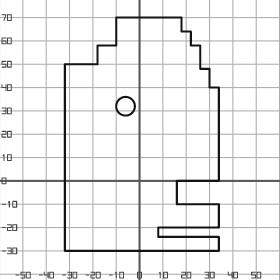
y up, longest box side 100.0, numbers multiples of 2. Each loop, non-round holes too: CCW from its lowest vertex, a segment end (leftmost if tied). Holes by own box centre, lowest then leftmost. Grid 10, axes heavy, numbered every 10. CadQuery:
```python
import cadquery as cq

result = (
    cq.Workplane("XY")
    .moveTo(-32.0, -30.0)
    .lineTo(34.0, -30.0)
    .lineTo(34.0, -24.0)
    .lineTo(8.0, -24.0)
    .lineTo(8.0, -20.0)
    .lineTo(34.0, -20.0)
    .lineTo(34.0, -10.0)
    .lineTo(16.0, -10.0)
    .lineTo(16.0, 0.0)
    .lineTo(34.0, 0.0)
    .lineTo(34.0, 40.0)
    .lineTo(30.0, 40.0)
    .lineTo(30.0, 48.0)
    .lineTo(26.0, 48.0)
    .lineTo(26.0, 58.0)
    .lineTo(22.0, 58.0)
    .lineTo(22.0, 64.0)
    .lineTo(18.0, 64.0)
    .lineTo(18.0, 70.0)
    .lineTo(-10.0, 70.0)
    .lineTo(-10.0, 58.0)
    .lineTo(-18.0, 58.0)
    .lineTo(-18.0, 50.0)
    .lineTo(-32.0, 50.0)
    .close()
    .moveTo(-6.0, 32.0)
    .circle(4.0)
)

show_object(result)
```